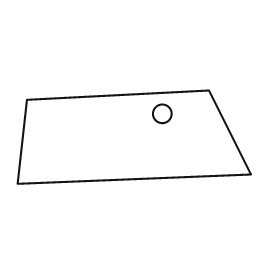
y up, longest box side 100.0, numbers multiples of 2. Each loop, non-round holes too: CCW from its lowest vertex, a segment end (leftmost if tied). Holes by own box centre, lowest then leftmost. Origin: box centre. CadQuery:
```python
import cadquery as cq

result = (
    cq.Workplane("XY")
    .moveTo(-50.0, -20.0)
    .lineTo(50.0, -16.0)
    .lineTo(32.0, 20.0)
    .lineTo(-46.0, 16.0)
    .close()
    .moveTo(12.0, 10.0)
    .circle(4.0)
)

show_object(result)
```